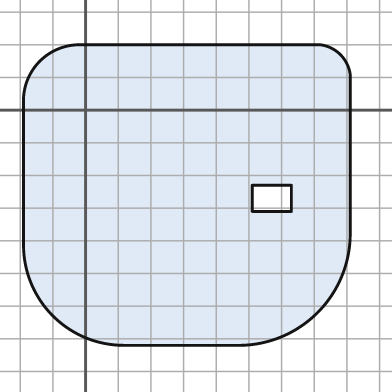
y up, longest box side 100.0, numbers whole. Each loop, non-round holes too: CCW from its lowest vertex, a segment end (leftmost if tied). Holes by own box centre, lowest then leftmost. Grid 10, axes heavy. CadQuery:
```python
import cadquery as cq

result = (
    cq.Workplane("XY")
    .moveTo(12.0, -72.0)
    .lineTo(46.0, -72.0)
    .threePointArc((71.0, -62.0), (81.0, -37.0))
    .lineTo(81.0, 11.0)
    .threePointArc((78.0, 17.0), (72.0, 20.0))
    .lineTo(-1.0, 20.0)
    .threePointArc((-14.0, 15.0), (-19.0, 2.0))
    .lineTo(-19.0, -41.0)
    .threePointArc((-10.0, -63.0), (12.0, -72.0))
    .close()
    .moveTo(51.0, -31.0)
    .lineTo(63.0, -31.0)
    .lineTo(63.0, -23.0)
    .lineTo(51.0, -23.0)
    .close()
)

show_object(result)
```